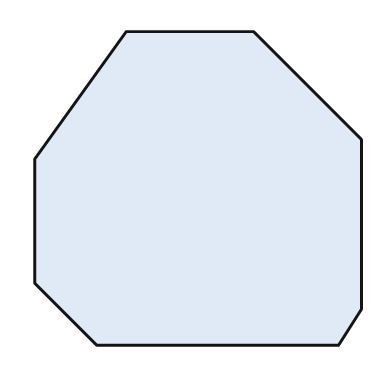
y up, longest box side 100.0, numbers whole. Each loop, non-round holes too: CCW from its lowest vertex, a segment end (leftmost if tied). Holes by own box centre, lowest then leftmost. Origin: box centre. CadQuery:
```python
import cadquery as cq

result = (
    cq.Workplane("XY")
    .moveTo(-31.0, -48.0)
    .lineTo(43.0, -48.0)
    .lineTo(50.0, -37.0)
    .lineTo(50.0, 15.0)
    .lineTo(17.0, 48.0)
    .lineTo(-22.0, 48.0)
    .lineTo(-50.0, 9.0)
    .lineTo(-50.0, -29.0)
    .close()
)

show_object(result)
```